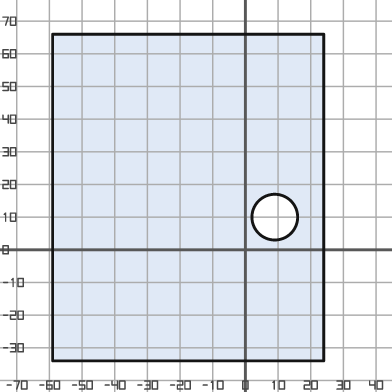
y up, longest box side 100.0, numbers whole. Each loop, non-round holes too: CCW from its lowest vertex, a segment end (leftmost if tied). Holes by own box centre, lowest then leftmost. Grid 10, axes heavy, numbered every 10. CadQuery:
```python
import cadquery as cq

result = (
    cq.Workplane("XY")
    .moveTo(-59.0, -34.0)
    .lineTo(24.0, -34.0)
    .lineTo(24.0, 66.0)
    .lineTo(-59.0, 66.0)
    .close()
    .moveTo(9.0, 10.0)
    .circle(7.0)
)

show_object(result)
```